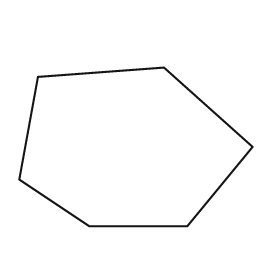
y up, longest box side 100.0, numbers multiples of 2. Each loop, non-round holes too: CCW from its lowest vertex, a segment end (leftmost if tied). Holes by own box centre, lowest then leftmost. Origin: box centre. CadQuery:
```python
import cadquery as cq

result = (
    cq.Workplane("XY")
    .moveTo(-20.0, -34.0)
    .lineTo(22.0, -34.0)
    .lineTo(50.0, 0.0)
    .lineTo(12.0, 34.0)
    .lineTo(-42.0, 30.0)
    .lineTo(-50.0, -14.0)
    .close()
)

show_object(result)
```